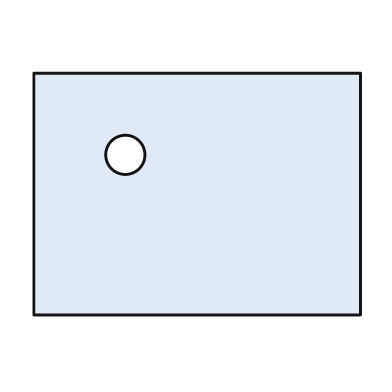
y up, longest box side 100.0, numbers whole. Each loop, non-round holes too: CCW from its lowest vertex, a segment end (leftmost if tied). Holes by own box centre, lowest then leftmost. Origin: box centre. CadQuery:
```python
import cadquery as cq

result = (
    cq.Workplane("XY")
    .moveTo(-50.0, -37.0)
    .lineTo(50.0, -37.0)
    .lineTo(50.0, 37.0)
    .lineTo(-50.0, 37.0)
    .close()
    .moveTo(-22.0, 12.0)
    .circle(6.0)
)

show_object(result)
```